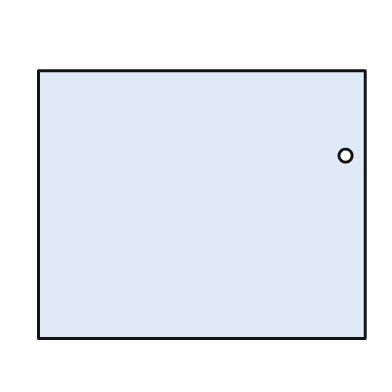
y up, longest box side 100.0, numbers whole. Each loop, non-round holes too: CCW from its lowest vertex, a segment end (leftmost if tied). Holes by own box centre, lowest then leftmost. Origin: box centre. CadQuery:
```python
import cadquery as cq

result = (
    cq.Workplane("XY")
    .moveTo(-50.0, -41.0)
    .lineTo(50.0, -41.0)
    .lineTo(50.0, 41.0)
    .lineTo(-50.0, 41.0)
    .close()
    .moveTo(44.0, 15.0)
    .circle(2.0)
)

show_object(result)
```